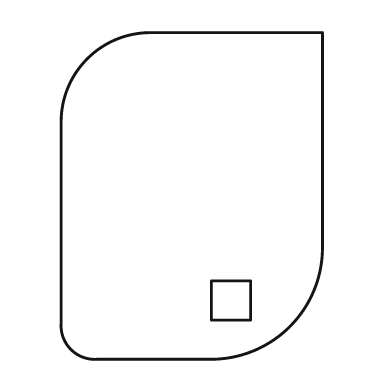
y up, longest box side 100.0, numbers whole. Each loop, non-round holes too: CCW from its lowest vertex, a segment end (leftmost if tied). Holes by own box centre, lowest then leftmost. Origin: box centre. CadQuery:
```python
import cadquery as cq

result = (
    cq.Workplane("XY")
    .moveTo(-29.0, -50.0)
    .lineTo(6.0, -50.0)
    .threePointArc((30.0, -40.0), (40.0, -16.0))
    .lineTo(40.0, 50.0)
    .lineTo(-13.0, 50.0)
    .threePointArc((-32.0, 42.0), (-40.0, 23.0))
    .lineTo(-40.0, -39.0)
    .threePointArc((-37.0, -47.0), (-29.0, -50.0))
    .close()
    .moveTo(6.0, -38.0)
    .lineTo(18.0, -38.0)
    .lineTo(18.0, -26.0)
    .lineTo(6.0, -26.0)
    .close()
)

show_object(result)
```